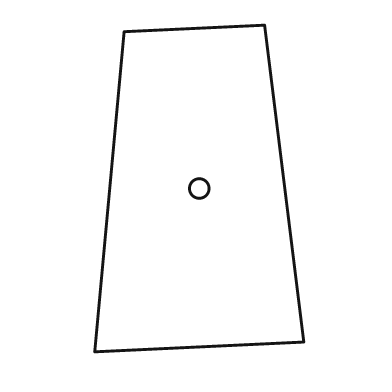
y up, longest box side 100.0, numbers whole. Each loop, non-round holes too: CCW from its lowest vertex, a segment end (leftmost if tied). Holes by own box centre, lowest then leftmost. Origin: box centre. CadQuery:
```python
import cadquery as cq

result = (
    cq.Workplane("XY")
    .moveTo(-32.0, -50.0)
    .lineTo(32.0, -47.0)
    .lineTo(20.0, 50.0)
    .lineTo(-23.0, 48.0)
    .close()
    .moveTo(0.0, 0.0)
    .circle(3.0)
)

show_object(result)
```